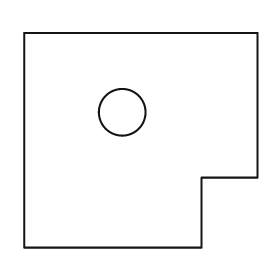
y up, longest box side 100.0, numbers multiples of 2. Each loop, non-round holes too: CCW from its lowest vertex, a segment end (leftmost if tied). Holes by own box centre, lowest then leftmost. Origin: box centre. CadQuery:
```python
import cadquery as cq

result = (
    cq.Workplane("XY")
    .moveTo(-50.0, -46.0)
    .lineTo(26.0, -46.0)
    .lineTo(26.0, -16.0)
    .lineTo(50.0, -16.0)
    .lineTo(50.0, 46.0)
    .lineTo(-50.0, 46.0)
    .close()
    .moveTo(-8.0, 12.0)
    .circle(10.0)
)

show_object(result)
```